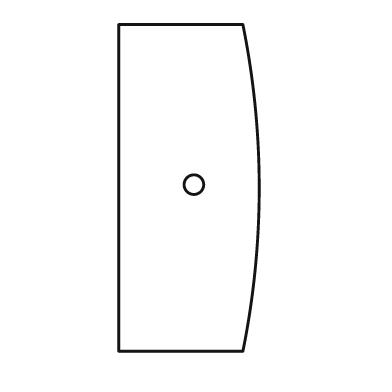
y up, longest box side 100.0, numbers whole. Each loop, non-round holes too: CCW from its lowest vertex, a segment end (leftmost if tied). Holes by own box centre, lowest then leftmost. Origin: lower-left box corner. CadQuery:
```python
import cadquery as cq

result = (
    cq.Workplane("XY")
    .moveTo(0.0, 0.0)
    .lineTo(38.0, 0.0)
    .threePointArc((43.0, 50.0), (38.0, 100.0))
    .lineTo(0.0, 100.0)
    .close()
    .moveTo(23.0, 51.0)
    .circle(3.0)
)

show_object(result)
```